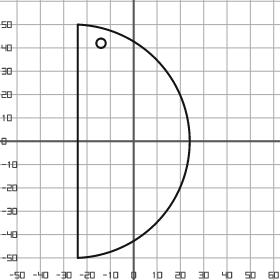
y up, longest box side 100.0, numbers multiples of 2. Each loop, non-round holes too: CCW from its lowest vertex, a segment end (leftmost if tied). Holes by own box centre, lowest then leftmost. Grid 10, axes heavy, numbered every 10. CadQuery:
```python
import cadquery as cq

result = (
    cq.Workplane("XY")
    .moveTo(-24.0, -50.0)
    .threePointArc((24.0, 0.0), (-24.0, 50.0))
    .close()
    .moveTo(-14.0, 42.0)
    .circle(2.0)
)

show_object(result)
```